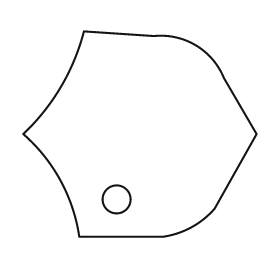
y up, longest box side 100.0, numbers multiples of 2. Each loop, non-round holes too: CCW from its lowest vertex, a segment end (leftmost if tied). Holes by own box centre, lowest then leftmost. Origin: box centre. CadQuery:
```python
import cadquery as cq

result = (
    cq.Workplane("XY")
    .moveTo(-26.0, -44.0)
    .lineTo(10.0, -44.0)
    .threePointArc((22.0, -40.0), (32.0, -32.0))
    .lineTo(50.0, 0.0)
    .lineTo(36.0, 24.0)
    .threePointArc((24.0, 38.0), (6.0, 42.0))
    .lineTo(-24.0, 44.0)
    .threePointArc((-34.0, 20.0), (-50.0, 0.0))
    .threePointArc((-34.0, -20.0), (-26.0, -44.0))
    .close()
    .moveTo(-10.0, -28.0)
    .circle(6.0)
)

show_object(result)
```